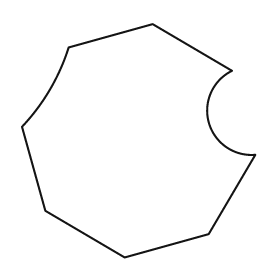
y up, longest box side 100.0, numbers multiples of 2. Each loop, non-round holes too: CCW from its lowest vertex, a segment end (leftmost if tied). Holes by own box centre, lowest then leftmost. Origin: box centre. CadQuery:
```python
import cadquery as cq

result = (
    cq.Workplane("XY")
    .moveTo(-6.0, -50.0)
    .lineTo(30.0, -40.0)
    .lineTo(50.0, -6.0)
    .threePointArc((30.0, 8.0), (40.0, 30.0))
    .lineTo(6.0, 50.0)
    .lineTo(-30.0, 40.0)
    .threePointArc((-38.0, 22.0), (-50.0, 6.0))
    .lineTo(-40.0, -30.0)
    .close()
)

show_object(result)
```